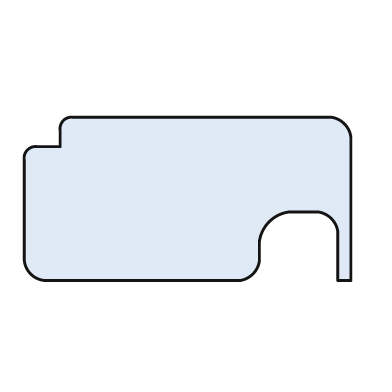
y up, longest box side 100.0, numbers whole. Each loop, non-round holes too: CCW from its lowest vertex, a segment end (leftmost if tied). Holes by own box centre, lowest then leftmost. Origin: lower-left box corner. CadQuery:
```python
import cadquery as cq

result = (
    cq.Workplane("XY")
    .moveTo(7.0, 0.0)
    .lineTo(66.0, 0.0)
    .threePointArc((70.0, 2.0), (72.0, 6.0))
    .lineTo(72.0, 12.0)
    .threePointArc((75.0, 18.0), (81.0, 21.0))
    .lineTo(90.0, 21.0)
    .threePointArc((94.0, 19.0), (96.0, 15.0))
    .lineTo(96.0, 0.0)
    .lineTo(100.0, 0.0)
    .lineTo(100.0, 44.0)
    .threePointArc((98.0, 48.0), (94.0, 50.0))
    .lineTo(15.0, 50.0)
    .threePointArc((12.0, 49.0), (11.0, 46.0))
    .lineTo(11.0, 41.0)
    .lineTo(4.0, 41.0)
    .threePointArc((1.0, 40.0), (0.0, 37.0))
    .lineTo(0.0, 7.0)
    .threePointArc((2.0, 2.0), (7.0, 0.0))
    .close()
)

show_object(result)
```